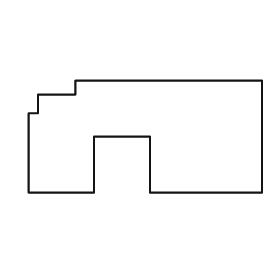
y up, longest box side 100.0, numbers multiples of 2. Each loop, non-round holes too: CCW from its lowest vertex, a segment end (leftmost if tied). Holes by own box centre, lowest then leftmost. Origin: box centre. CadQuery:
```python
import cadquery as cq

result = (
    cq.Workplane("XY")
    .moveTo(-50.0, -24.0)
    .lineTo(-22.0, -24.0)
    .lineTo(-22.0, 0.0)
    .lineTo(2.0, 0.0)
    .lineTo(2.0, -24.0)
    .lineTo(50.0, -24.0)
    .lineTo(50.0, 24.0)
    .lineTo(-30.0, 24.0)
    .lineTo(-30.0, 18.0)
    .lineTo(-46.0, 18.0)
    .lineTo(-46.0, 10.0)
    .lineTo(-50.0, 10.0)
    .close()
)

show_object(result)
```